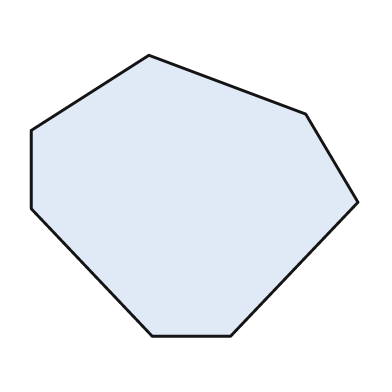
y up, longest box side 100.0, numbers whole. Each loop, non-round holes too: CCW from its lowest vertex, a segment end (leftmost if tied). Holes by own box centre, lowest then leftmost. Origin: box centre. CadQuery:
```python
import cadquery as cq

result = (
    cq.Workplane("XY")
    .moveTo(-13.0, -43.0)
    .lineTo(11.0, -43.0)
    .lineTo(50.0, -2.0)
    .lineTo(34.0, 25.0)
    .lineTo(-14.0, 43.0)
    .lineTo(-50.0, 20.0)
    .lineTo(-50.0, -4.0)
    .close()
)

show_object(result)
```